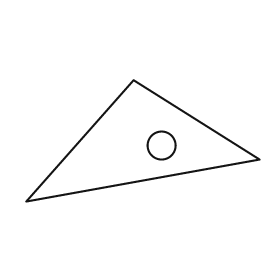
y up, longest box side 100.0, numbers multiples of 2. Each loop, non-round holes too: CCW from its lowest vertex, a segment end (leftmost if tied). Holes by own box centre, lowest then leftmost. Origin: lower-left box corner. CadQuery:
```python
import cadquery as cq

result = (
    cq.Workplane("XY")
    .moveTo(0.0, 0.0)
    .lineTo(100.0, 18.0)
    .lineTo(46.0, 52.0)
    .close()
    .moveTo(58.0, 24.0)
    .circle(6.0)
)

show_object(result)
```